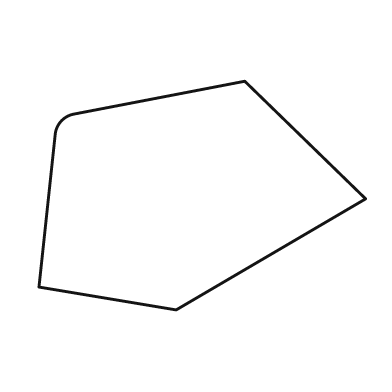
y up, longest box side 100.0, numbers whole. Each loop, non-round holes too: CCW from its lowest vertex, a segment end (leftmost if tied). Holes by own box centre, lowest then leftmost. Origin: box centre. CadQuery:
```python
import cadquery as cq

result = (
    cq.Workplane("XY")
    .moveTo(-8.0, -35.0)
    .lineTo(50.0, -1.0)
    .lineTo(13.0, 35.0)
    .lineTo(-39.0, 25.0)
    .threePointArc((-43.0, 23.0), (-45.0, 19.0))
    .lineTo(-50.0, -28.0)
    .close()
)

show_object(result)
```